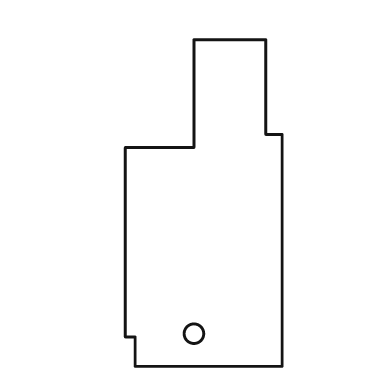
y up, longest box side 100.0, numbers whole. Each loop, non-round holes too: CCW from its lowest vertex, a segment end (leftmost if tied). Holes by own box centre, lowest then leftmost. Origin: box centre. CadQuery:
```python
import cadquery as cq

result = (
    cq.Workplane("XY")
    .moveTo(-21.0, -50.0)
    .lineTo(24.0, -50.0)
    .lineTo(24.0, 21.0)
    .lineTo(19.0, 21.0)
    .lineTo(19.0, 50.0)
    .lineTo(-3.0, 50.0)
    .lineTo(-3.0, 17.0)
    .lineTo(-24.0, 17.0)
    .lineTo(-24.0, -41.0)
    .lineTo(-21.0, -41.0)
    .close()
    .moveTo(-3.0, -40.0)
    .circle(3.0)
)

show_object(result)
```